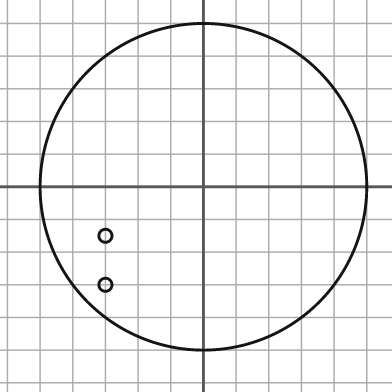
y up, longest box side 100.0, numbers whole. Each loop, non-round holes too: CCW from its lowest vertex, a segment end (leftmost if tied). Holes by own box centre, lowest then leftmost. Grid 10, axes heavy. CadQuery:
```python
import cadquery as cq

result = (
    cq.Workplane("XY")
    .moveTo(0.0, 0.0)
    .circle(50.0)
    .moveTo(-30.0, -30.0)
    .circle(2.0)
    .moveTo(-30.0, -15.0)
    .circle(2.0)
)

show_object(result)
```